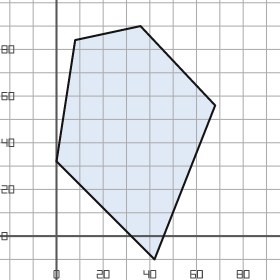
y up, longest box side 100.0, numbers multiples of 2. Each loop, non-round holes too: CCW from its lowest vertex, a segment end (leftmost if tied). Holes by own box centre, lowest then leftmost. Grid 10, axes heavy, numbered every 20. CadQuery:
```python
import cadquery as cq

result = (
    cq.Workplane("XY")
    .moveTo(42.0, -10.0)
    .lineTo(68.0, 56.0)
    .lineTo(36.0, 90.0)
    .lineTo(8.0, 84.0)
    .lineTo(0.0, 32.0)
    .close()
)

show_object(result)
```